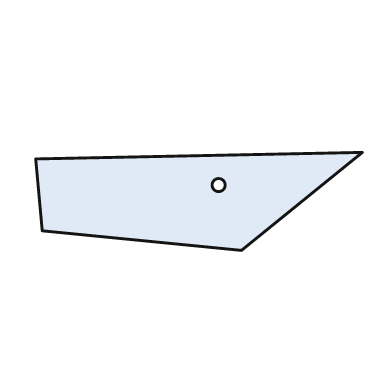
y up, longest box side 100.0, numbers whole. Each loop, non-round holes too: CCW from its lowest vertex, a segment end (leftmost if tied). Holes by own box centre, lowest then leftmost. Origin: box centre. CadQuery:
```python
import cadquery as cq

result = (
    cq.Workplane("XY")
    .moveTo(13.0, -15.0)
    .lineTo(50.0, 15.0)
    .lineTo(-50.0, 13.0)
    .lineTo(-48.0, -9.0)
    .close()
    .moveTo(6.0, 5.0)
    .circle(2.0)
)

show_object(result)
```